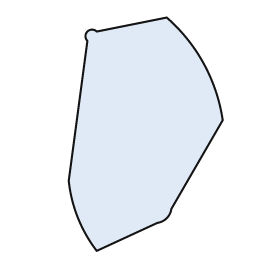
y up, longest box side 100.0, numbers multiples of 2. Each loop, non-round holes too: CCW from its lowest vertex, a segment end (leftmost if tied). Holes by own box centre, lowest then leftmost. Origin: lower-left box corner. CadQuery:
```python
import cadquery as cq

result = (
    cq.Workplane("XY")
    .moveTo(12.0, 0.0)
    .lineTo(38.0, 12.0)
    .threePointArc((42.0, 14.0), (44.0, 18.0))
    .lineTo(66.0, 56.0)
    .threePointArc((58.0, 80.0), (42.0, 100.0))
    .lineTo(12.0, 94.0)
    .threePointArc((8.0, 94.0), (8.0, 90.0))
    .lineTo(0.0, 30.0)
    .threePointArc((4.0, 14.0), (12.0, 0.0))
    .close()
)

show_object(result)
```